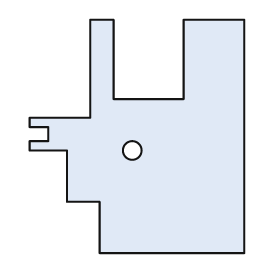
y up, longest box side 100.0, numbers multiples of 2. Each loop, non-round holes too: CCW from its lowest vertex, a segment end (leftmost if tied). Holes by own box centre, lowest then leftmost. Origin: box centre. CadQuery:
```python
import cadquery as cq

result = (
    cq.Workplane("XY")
    .moveTo(-16.0, -50.0)
    .lineTo(46.0, -50.0)
    .lineTo(46.0, 50.0)
    .lineTo(20.0, 50.0)
    .lineTo(20.0, 16.0)
    .lineTo(-10.0, 16.0)
    .lineTo(-10.0, 50.0)
    .lineTo(-20.0, 50.0)
    .lineTo(-20.0, 8.0)
    .lineTo(-46.0, 8.0)
    .lineTo(-46.0, 4.0)
    .lineTo(-38.0, 4.0)
    .lineTo(-38.0, -2.0)
    .lineTo(-46.0, -2.0)
    .lineTo(-46.0, -6.0)
    .lineTo(-30.0, -6.0)
    .lineTo(-30.0, -28.0)
    .lineTo(-16.0, -28.0)
    .close()
    .moveTo(-2.0, -6.0)
    .circle(4.0)
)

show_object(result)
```